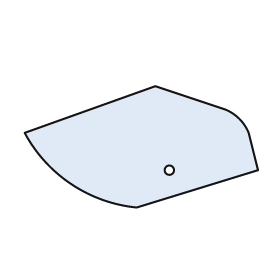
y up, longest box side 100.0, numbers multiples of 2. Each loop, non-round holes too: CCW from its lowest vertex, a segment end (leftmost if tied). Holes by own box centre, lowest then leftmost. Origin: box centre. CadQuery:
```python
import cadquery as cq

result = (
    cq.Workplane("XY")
    .moveTo(-2.0, -26.0)
    .lineTo(50.0, -10.0)
    .lineTo(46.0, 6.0)
    .threePointArc((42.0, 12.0), (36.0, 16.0))
    .lineTo(6.0, 26.0)
    .lineTo(-50.0, 6.0)
    .threePointArc((-30.0, -16.0), (-2.0, -26.0))
    .close()
    .moveTo(12.0, -10.0)
    .circle(2.0)
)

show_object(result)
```